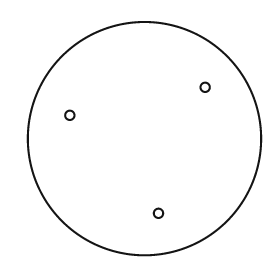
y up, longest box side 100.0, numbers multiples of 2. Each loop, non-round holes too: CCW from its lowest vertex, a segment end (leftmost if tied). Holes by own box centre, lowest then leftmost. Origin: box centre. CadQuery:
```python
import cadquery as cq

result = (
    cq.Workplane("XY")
    .moveTo(0.0, 0.0)
    .circle(50.0)
    .moveTo(6.0, -32.0)
    .circle(2.0)
    .moveTo(-32.0, 10.0)
    .circle(2.0)
    .moveTo(26.0, 22.0)
    .circle(2.0)
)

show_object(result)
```